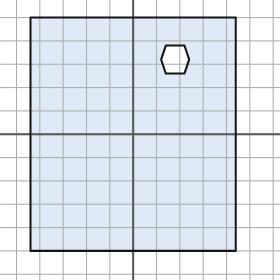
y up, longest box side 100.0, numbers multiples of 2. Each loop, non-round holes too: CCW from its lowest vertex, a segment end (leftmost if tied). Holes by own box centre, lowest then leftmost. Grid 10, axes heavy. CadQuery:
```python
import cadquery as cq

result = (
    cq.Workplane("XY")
    .moveTo(-44.0, -50.0)
    .lineTo(44.0, -50.0)
    .lineTo(44.0, 50.0)
    .lineTo(-44.0, 50.0)
    .close()
    .moveTo(14.0, 26.0)
    .lineTo(22.0, 26.0)
    .lineTo(24.0, 32.0)
    .lineTo(22.0, 38.0)
    .lineTo(14.0, 38.0)
    .lineTo(12.0, 32.0)
    .close()
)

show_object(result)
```